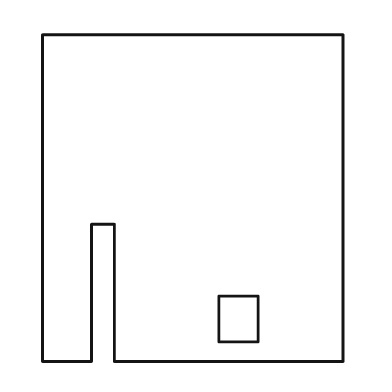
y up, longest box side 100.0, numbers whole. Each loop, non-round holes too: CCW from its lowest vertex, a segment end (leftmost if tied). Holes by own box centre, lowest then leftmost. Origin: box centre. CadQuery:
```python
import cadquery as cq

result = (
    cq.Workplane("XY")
    .moveTo(-46.0, -50.0)
    .lineTo(-31.0, -50.0)
    .lineTo(-31.0, -8.0)
    .lineTo(-24.0, -8.0)
    .lineTo(-24.0, -50.0)
    .lineTo(46.0, -50.0)
    .lineTo(46.0, 50.0)
    .lineTo(-46.0, 50.0)
    .close()
    .moveTo(8.0, -44.0)
    .lineTo(20.0, -44.0)
    .lineTo(20.0, -30.0)
    .lineTo(8.0, -30.0)
    .close()
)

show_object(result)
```